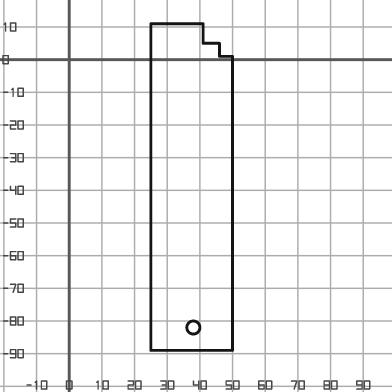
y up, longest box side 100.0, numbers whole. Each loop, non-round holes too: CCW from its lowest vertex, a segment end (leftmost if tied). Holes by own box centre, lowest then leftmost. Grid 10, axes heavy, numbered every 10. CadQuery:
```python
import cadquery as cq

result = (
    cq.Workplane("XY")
    .moveTo(25.0, -89.0)
    .lineTo(50.0, -89.0)
    .lineTo(50.0, 1.0)
    .lineTo(46.0, 1.0)
    .lineTo(46.0, 5.0)
    .lineTo(41.0, 5.0)
    .lineTo(41.0, 11.0)
    .lineTo(25.0, 11.0)
    .close()
    .moveTo(38.0, -82.0)
    .circle(2.0)
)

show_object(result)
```